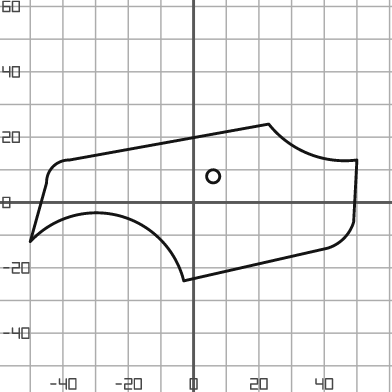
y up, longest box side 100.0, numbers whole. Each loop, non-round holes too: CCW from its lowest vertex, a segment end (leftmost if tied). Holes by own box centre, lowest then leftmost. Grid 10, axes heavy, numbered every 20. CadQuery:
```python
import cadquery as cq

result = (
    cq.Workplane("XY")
    .moveTo(-3.0, -24.0)
    .lineTo(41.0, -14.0)
    .threePointArc((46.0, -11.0), (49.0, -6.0))
    .lineTo(50.0, 13.0)
    .threePointArc((35.0, 15.0), (23.0, 24.0))
    .lineTo(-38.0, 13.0)
    .threePointArc((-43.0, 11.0), (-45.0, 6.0))
    .lineTo(-50.0, -12.0)
    .threePointArc((-23.0, -4.0), (-3.0, -24.0))
    .close()
    .moveTo(6.0, 8.0)
    .circle(2.0)
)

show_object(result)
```